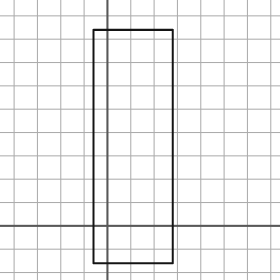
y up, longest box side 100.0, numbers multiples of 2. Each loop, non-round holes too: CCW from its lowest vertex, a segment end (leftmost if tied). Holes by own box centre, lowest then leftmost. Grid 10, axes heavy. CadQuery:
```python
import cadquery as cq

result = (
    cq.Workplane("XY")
    .moveTo(-6.0, -16.0)
    .lineTo(28.0, -16.0)
    .lineTo(28.0, 84.0)
    .lineTo(-6.0, 84.0)
    .close()
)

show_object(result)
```